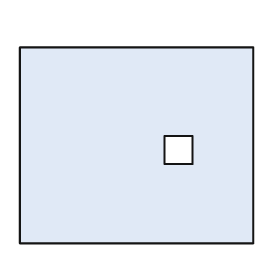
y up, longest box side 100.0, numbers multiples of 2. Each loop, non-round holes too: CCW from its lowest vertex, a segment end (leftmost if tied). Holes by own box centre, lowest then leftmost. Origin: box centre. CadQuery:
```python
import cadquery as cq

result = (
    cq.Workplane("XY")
    .moveTo(-50.0, -42.0)
    .lineTo(50.0, -42.0)
    .lineTo(50.0, 42.0)
    .lineTo(-50.0, 42.0)
    .close()
    .moveTo(12.0, -8.0)
    .lineTo(24.0, -8.0)
    .lineTo(24.0, 4.0)
    .lineTo(12.0, 4.0)
    .close()
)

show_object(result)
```